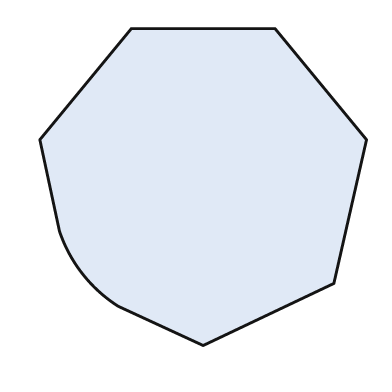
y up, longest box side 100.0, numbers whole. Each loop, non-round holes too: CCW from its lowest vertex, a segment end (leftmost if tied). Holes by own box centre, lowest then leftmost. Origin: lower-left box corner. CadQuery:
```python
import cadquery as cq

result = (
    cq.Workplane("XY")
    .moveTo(50.0, 0.0)
    .lineTo(90.0, 19.0)
    .lineTo(100.0, 63.0)
    .lineTo(72.0, 97.0)
    .lineTo(28.0, 97.0)
    .lineTo(0.0, 63.0)
    .lineTo(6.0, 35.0)
    .threePointArc((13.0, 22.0), (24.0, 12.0))
    .close()
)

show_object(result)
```